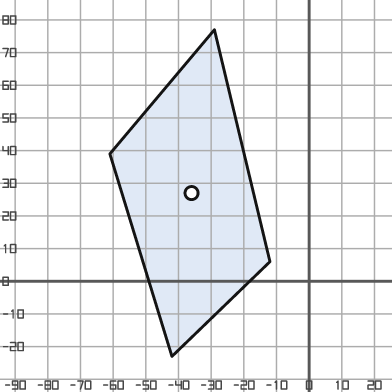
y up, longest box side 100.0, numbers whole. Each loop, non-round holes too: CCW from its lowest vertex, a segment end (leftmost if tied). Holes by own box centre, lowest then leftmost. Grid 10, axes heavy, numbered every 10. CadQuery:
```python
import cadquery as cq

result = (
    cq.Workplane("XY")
    .moveTo(-42.0, -23.0)
    .lineTo(-12.0, 6.0)
    .lineTo(-29.0, 77.0)
    .lineTo(-61.0, 39.0)
    .close()
    .moveTo(-36.0, 27.0)
    .circle(2.0)
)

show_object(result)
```